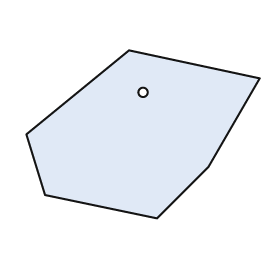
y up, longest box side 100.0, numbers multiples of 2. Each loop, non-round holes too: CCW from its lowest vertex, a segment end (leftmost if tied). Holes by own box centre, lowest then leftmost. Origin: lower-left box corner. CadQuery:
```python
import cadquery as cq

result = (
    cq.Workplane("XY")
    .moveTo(56.0, 0.0)
    .lineTo(78.0, 22.0)
    .lineTo(100.0, 60.0)
    .lineTo(44.0, 72.0)
    .lineTo(0.0, 36.0)
    .lineTo(8.0, 10.0)
    .close()
    .moveTo(50.0, 54.0)
    .circle(2.0)
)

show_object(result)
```